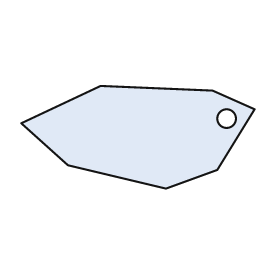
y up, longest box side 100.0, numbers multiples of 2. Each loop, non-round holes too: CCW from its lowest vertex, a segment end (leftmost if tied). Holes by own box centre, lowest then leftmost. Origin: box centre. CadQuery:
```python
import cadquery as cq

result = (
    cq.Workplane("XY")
    .moveTo(12.0, -22.0)
    .lineTo(34.0, -14.0)
    .lineTo(50.0, 12.0)
    .lineTo(32.0, 20.0)
    .lineTo(-16.0, 22.0)
    .lineTo(-50.0, 6.0)
    .lineTo(-30.0, -12.0)
    .close()
    .moveTo(38.0, 8.0)
    .circle(4.0)
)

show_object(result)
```